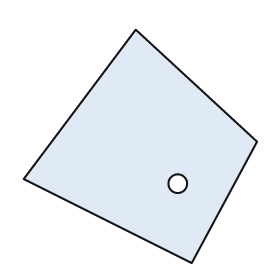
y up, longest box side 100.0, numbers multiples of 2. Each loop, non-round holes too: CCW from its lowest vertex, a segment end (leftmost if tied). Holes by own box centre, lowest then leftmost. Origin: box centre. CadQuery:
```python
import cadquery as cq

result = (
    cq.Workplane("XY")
    .moveTo(22.0, -50.0)
    .lineTo(50.0, 2.0)
    .lineTo(-2.0, 50.0)
    .lineTo(-50.0, -14.0)
    .close()
    .moveTo(16.0, -16.0)
    .circle(4.0)
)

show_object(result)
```